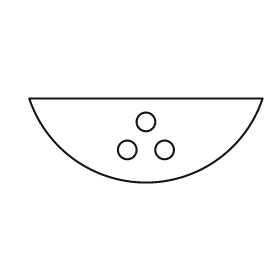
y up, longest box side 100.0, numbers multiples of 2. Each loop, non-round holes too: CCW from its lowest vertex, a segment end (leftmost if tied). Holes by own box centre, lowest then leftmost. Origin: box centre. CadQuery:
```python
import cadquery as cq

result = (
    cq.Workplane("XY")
    .moveTo(-50.0, 18.0)
    .threePointArc((0.0, -18.0), (50.0, 18.0))
    .close()
    .moveTo(-8.0, -4.0)
    .circle(4.0)
    .moveTo(8.0, -4.0)
    .circle(4.0)
    .moveTo(0.0, 8.0)
    .circle(4.0)
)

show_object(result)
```